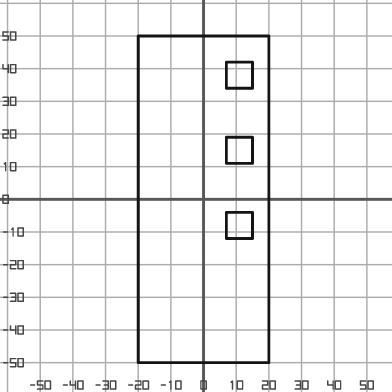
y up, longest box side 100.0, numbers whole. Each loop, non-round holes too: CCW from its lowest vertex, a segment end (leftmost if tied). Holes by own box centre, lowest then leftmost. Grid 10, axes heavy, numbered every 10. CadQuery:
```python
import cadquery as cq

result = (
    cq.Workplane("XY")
    .moveTo(-20.0, -50.0)
    .lineTo(20.0, -50.0)
    .lineTo(20.0, 50.0)
    .lineTo(-20.0, 50.0)
    .close()
    .moveTo(7.0, -12.0)
    .lineTo(15.0, -12.0)
    .lineTo(15.0, -4.0)
    .lineTo(7.0, -4.0)
    .close()
    .moveTo(7.0, 11.0)
    .lineTo(15.0, 11.0)
    .lineTo(15.0, 19.0)
    .lineTo(7.0, 19.0)
    .close()
    .moveTo(7.0, 34.0)
    .lineTo(15.0, 34.0)
    .lineTo(15.0, 42.0)
    .lineTo(7.0, 42.0)
    .close()
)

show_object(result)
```